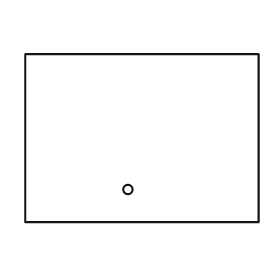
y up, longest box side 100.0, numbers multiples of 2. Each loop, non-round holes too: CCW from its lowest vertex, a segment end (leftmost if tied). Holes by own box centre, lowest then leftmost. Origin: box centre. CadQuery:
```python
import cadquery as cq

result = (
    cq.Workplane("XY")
    .moveTo(-50.0, -36.0)
    .lineTo(50.0, -36.0)
    .lineTo(50.0, 36.0)
    .lineTo(-50.0, 36.0)
    .close()
    .moveTo(-6.0, -22.0)
    .circle(2.0)
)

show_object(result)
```